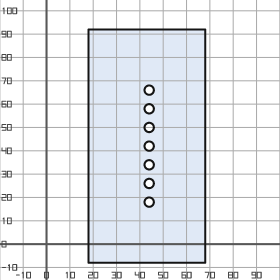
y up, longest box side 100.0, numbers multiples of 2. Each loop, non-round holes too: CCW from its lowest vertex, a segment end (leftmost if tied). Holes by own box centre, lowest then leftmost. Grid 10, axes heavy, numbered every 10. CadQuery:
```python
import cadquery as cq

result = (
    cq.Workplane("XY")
    .moveTo(18.0, -8.0)
    .lineTo(68.0, -8.0)
    .lineTo(68.0, 92.0)
    .lineTo(18.0, 92.0)
    .close()
    .moveTo(44.0, 18.0)
    .circle(2.0)
    .moveTo(44.0, 26.0)
    .circle(2.0)
    .moveTo(44.0, 34.0)
    .circle(2.0)
    .moveTo(44.0, 42.0)
    .circle(2.0)
    .moveTo(44.0, 50.0)
    .circle(2.0)
    .moveTo(44.0, 58.0)
    .circle(2.0)
    .moveTo(44.0, 66.0)
    .circle(2.0)
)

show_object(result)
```